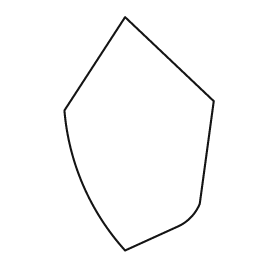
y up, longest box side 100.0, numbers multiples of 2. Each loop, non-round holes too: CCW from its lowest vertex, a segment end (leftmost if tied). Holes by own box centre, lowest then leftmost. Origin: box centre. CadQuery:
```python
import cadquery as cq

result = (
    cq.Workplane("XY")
    .moveTo(-6.0, -50.0)
    .lineTo(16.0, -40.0)
    .threePointArc((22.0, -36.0), (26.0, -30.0))
    .lineTo(32.0, 14.0)
    .lineTo(-6.0, 50.0)
    .lineTo(-32.0, 10.0)
    .threePointArc((-24.0, -22.0), (-6.0, -50.0))
    .close()
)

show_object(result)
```